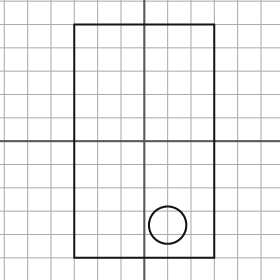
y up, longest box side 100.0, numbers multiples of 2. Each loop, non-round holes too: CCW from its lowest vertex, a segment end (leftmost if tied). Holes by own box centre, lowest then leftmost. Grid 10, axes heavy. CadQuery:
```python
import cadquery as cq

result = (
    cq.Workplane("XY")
    .moveTo(-30.0, -50.0)
    .lineTo(30.0, -50.0)
    .lineTo(30.0, 50.0)
    .lineTo(-30.0, 50.0)
    .close()
    .moveTo(10.0, -36.0)
    .circle(8.0)
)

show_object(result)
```